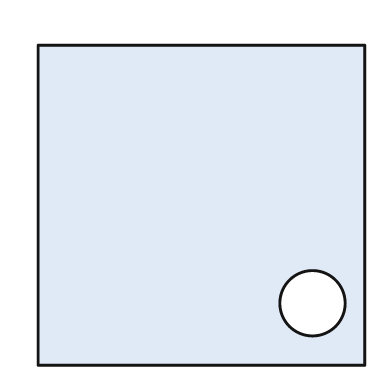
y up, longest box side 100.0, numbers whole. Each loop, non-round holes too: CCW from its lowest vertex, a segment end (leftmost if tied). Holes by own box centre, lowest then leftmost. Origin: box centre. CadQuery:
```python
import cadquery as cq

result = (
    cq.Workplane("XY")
    .moveTo(-50.0, -49.0)
    .lineTo(50.0, -49.0)
    .lineTo(50.0, 49.0)
    .lineTo(-50.0, 49.0)
    .close()
    .moveTo(34.0, -30.0)
    .circle(10.0)
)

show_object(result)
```